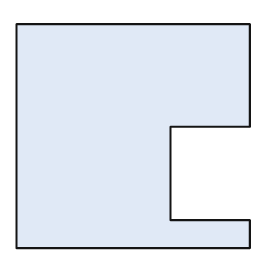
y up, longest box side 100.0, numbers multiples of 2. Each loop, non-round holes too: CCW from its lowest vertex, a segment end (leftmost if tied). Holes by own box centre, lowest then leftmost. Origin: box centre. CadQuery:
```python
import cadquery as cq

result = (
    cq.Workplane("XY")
    .moveTo(-50.0, -48.0)
    .lineTo(50.0, -48.0)
    .lineTo(50.0, -36.0)
    .lineTo(16.0, -36.0)
    .lineTo(16.0, 4.0)
    .lineTo(50.0, 4.0)
    .lineTo(50.0, 48.0)
    .lineTo(-50.0, 48.0)
    .close()
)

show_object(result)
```